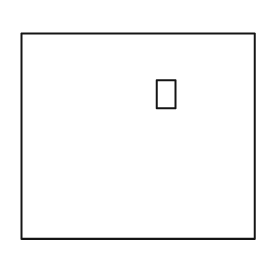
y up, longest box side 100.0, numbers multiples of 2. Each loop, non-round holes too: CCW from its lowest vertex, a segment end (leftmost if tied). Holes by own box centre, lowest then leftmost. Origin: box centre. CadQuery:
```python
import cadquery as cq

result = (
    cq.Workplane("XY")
    .moveTo(-50.0, -44.0)
    .lineTo(50.0, -44.0)
    .lineTo(50.0, 44.0)
    .lineTo(-50.0, 44.0)
    .close()
    .moveTo(8.0, 12.0)
    .lineTo(16.0, 12.0)
    .lineTo(16.0, 24.0)
    .lineTo(8.0, 24.0)
    .close()
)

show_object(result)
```